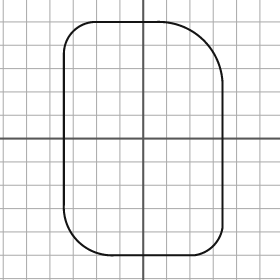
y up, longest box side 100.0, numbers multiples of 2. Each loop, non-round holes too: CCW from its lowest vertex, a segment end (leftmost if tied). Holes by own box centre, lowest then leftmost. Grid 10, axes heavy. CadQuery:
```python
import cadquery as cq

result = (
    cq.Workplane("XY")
    .moveTo(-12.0, -50.0)
    .lineTo(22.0, -50.0)
    .threePointArc((30.0, -46.0), (34.0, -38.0))
    .lineTo(34.0, 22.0)
    .threePointArc((26.0, 42.0), (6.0, 50.0))
    .lineTo(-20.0, 50.0)
    .threePointArc((-30.0, 46.0), (-34.0, 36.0))
    .lineTo(-34.0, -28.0)
    .threePointArc((-28.0, -44.0), (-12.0, -50.0))
    .close()
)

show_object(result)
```